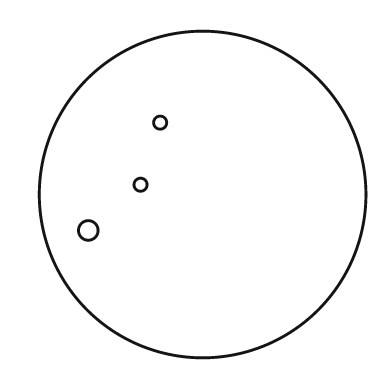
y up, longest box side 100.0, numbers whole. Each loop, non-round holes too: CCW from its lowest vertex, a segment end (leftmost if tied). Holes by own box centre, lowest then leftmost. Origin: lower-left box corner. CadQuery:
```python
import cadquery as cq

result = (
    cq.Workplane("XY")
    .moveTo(50.0, 50.0)
    .circle(50.0)
    .moveTo(15.0, 39.0)
    .circle(3.0)
    .moveTo(31.0, 53.0)
    .circle(2.0)
    .moveTo(37.0, 72.0)
    .circle(2.0)
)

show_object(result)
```